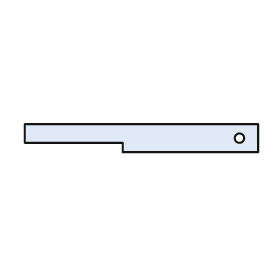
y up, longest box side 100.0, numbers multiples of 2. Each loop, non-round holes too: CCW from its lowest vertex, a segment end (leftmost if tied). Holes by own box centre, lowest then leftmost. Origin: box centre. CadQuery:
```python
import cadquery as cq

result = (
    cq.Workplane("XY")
    .moveTo(-8.0, -6.0)
    .lineTo(50.0, -6.0)
    .lineTo(50.0, 6.0)
    .lineTo(-50.0, 6.0)
    .lineTo(-50.0, -2.0)
    .lineTo(-8.0, -2.0)
    .close()
    .moveTo(42.0, 0.0)
    .circle(2.0)
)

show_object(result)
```